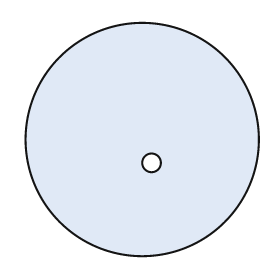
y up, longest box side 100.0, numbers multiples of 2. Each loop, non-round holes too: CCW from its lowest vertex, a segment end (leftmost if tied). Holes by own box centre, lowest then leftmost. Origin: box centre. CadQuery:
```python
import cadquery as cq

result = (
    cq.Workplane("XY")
    .moveTo(0.0, 0.0)
    .circle(50.0)
    .moveTo(4.0, -10.0)
    .circle(4.0)
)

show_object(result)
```